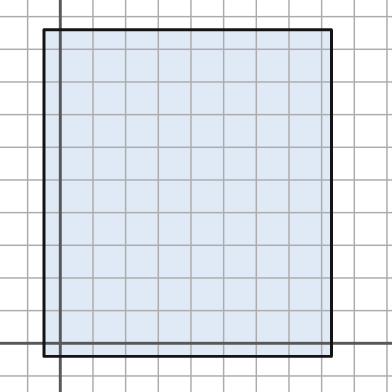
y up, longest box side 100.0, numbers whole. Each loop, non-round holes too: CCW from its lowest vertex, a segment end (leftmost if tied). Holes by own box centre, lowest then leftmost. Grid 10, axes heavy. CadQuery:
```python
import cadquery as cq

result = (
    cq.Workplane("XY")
    .moveTo(-5.0, -4.0)
    .lineTo(83.0, -4.0)
    .lineTo(83.0, 96.0)
    .lineTo(-5.0, 96.0)
    .close()
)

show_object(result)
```